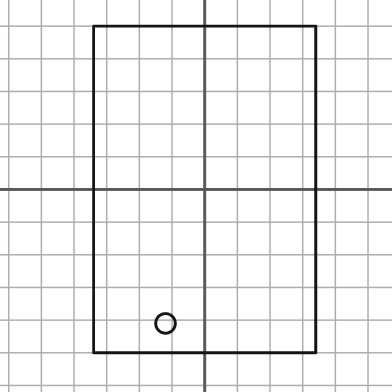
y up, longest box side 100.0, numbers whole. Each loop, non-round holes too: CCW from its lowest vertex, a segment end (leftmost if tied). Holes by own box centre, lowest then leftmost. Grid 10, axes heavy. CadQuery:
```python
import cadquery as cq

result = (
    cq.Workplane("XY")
    .moveTo(-34.0, -50.0)
    .lineTo(34.0, -50.0)
    .lineTo(34.0, 50.0)
    .lineTo(-34.0, 50.0)
    .close()
    .moveTo(-12.0, -41.0)
    .circle(3.0)
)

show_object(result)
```